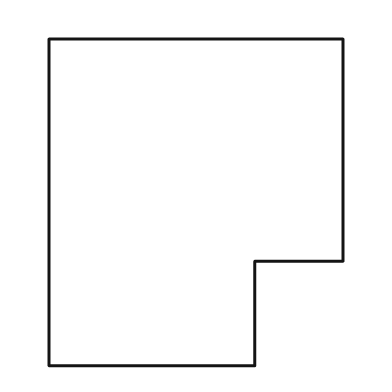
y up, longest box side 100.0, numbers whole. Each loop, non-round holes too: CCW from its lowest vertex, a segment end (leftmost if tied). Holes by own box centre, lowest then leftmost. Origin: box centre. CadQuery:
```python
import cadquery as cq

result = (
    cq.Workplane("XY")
    .moveTo(-45.0, -50.0)
    .lineTo(18.0, -50.0)
    .lineTo(18.0, -18.0)
    .lineTo(45.0, -18.0)
    .lineTo(45.0, 50.0)
    .lineTo(-45.0, 50.0)
    .close()
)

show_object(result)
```